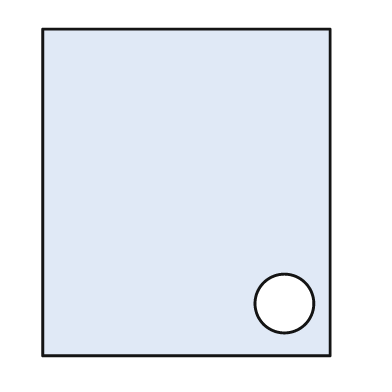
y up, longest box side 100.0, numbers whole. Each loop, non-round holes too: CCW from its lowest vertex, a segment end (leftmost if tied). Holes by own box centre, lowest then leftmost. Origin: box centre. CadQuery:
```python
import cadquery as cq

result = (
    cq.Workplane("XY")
    .moveTo(-44.0, -50.0)
    .lineTo(44.0, -50.0)
    .lineTo(44.0, 50.0)
    .lineTo(-44.0, 50.0)
    .close()
    .moveTo(30.0, -34.0)
    .circle(9.0)
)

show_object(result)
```